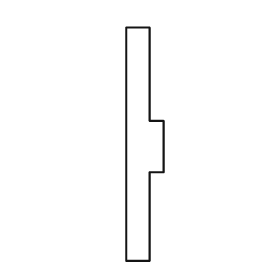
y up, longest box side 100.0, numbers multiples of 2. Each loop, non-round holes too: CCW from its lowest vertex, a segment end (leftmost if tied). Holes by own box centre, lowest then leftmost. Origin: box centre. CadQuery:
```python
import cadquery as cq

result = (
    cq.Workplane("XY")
    .moveTo(-8.0, -50.0)
    .lineTo(2.0, -50.0)
    .lineTo(2.0, -12.0)
    .lineTo(8.0, -12.0)
    .lineTo(8.0, 10.0)
    .lineTo(2.0, 10.0)
    .lineTo(2.0, 50.0)
    .lineTo(-8.0, 50.0)
    .close()
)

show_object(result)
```